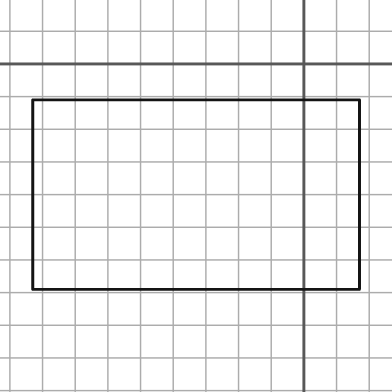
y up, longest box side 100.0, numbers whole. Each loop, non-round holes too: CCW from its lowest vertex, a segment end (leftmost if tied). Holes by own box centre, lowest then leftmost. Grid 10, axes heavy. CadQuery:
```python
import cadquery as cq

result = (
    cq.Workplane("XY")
    .moveTo(-83.0, -69.0)
    .lineTo(17.0, -69.0)
    .lineTo(17.0, -11.0)
    .lineTo(-83.0, -11.0)
    .close()
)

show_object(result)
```